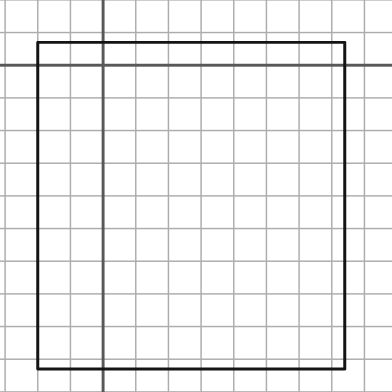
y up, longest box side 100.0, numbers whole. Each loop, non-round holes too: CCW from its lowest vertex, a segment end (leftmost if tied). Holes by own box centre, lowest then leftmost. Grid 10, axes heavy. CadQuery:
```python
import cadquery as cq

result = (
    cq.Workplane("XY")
    .moveTo(-20.0, -93.0)
    .lineTo(74.0, -93.0)
    .lineTo(74.0, 7.0)
    .lineTo(-20.0, 7.0)
    .close()
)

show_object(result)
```